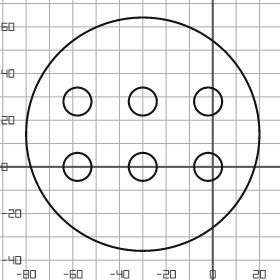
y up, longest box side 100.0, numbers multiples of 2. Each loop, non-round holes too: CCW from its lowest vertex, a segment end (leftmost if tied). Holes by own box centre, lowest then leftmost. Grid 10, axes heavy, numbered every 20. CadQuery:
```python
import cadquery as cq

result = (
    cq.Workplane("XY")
    .moveTo(-30.0, 14.0)
    .circle(50.0)
    .moveTo(-58.0, 0.0)
    .circle(6.0)
    .moveTo(-30.0, 0.0)
    .circle(6.0)
    .moveTo(-2.0, 0.0)
    .circle(6.0)
    .moveTo(-58.0, 28.0)
    .circle(6.0)
    .moveTo(-30.0, 28.0)
    .circle(6.0)
    .moveTo(-2.0, 28.0)
    .circle(6.0)
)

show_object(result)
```